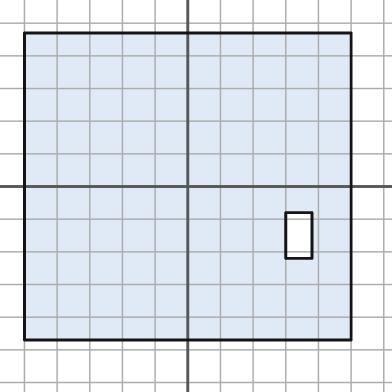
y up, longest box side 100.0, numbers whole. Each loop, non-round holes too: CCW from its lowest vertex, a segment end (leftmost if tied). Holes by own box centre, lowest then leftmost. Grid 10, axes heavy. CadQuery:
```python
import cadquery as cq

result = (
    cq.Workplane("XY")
    .moveTo(-50.0, -47.0)
    .lineTo(50.0, -47.0)
    .lineTo(50.0, 47.0)
    .lineTo(-50.0, 47.0)
    .close()
    .moveTo(30.0, -22.0)
    .lineTo(38.0, -22.0)
    .lineTo(38.0, -8.0)
    .lineTo(30.0, -8.0)
    .close()
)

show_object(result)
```